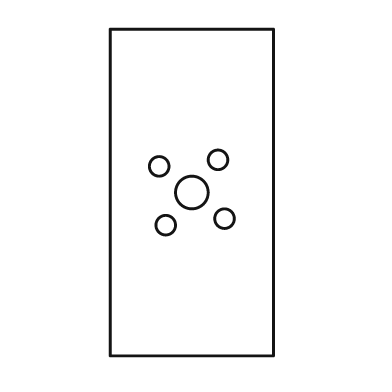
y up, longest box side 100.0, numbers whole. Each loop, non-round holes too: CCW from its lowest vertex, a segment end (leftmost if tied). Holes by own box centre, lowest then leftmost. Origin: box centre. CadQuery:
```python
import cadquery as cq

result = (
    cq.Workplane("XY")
    .moveTo(-25.0, -50.0)
    .lineTo(25.0, -50.0)
    .lineTo(25.0, 50.0)
    .lineTo(-25.0, 50.0)
    .close()
    .moveTo(-8.0, -10.0)
    .circle(3.0)
    .moveTo(10.0, -8.0)
    .circle(3.0)
    .moveTo(0.0, 0.0)
    .circle(5.0)
    .moveTo(-10.0, 8.0)
    .circle(3.0)
    .moveTo(8.0, 10.0)
    .circle(3.0)
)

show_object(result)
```